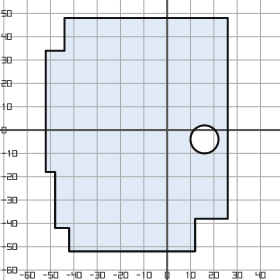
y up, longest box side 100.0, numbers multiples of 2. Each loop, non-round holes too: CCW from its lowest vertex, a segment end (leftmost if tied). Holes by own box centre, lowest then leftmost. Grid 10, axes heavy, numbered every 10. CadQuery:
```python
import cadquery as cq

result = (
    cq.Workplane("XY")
    .moveTo(-42.0, -52.0)
    .lineTo(12.0, -52.0)
    .lineTo(12.0, -38.0)
    .lineTo(26.0, -38.0)
    .lineTo(26.0, 48.0)
    .lineTo(-44.0, 48.0)
    .lineTo(-44.0, 34.0)
    .lineTo(-52.0, 34.0)
    .lineTo(-52.0, -18.0)
    .lineTo(-48.0, -18.0)
    .lineTo(-48.0, -42.0)
    .lineTo(-42.0, -42.0)
    .close()
    .moveTo(16.0, -4.0)
    .circle(6.0)
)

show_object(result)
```